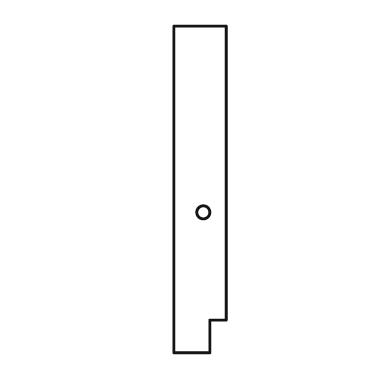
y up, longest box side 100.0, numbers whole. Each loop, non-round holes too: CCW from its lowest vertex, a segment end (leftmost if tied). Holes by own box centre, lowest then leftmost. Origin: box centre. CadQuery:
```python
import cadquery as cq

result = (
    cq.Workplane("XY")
    .moveTo(-8.0, -50.0)
    .lineTo(3.0, -50.0)
    .lineTo(3.0, -40.0)
    .lineTo(8.0, -40.0)
    .lineTo(8.0, 50.0)
    .lineTo(-8.0, 50.0)
    .close()
    .moveTo(1.0, -7.0)
    .circle(2.0)
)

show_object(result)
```